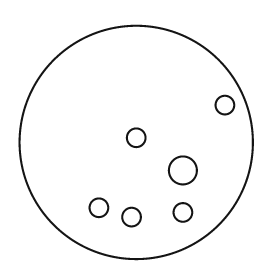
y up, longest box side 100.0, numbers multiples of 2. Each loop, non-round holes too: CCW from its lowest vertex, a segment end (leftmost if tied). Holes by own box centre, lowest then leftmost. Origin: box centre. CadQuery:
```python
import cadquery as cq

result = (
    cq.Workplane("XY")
    .moveTo(0.0, 0.0)
    .circle(50.0)
    .moveTo(-2.0, -32.0)
    .circle(4.0)
    .moveTo(20.0, -30.0)
    .circle(4.0)
    .moveTo(-16.0, -28.0)
    .circle(4.0)
    .moveTo(20.0, -12.0)
    .circle(6.0)
    .moveTo(0.0, 2.0)
    .circle(4.0)
    .moveTo(38.0, 16.0)
    .circle(4.0)
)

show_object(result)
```